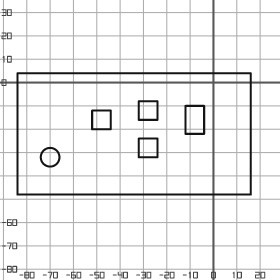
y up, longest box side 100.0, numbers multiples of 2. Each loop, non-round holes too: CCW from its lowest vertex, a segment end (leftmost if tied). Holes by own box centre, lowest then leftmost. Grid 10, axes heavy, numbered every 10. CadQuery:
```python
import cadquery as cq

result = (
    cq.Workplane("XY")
    .moveTo(-84.0, -48.0)
    .lineTo(16.0, -48.0)
    .lineTo(16.0, 4.0)
    .lineTo(-84.0, 4.0)
    .close()
    .moveTo(-70.0, -32.0)
    .circle(4.0)
    .moveTo(-32.0, -32.0)
    .lineTo(-24.0, -32.0)
    .lineTo(-24.0, -24.0)
    .lineTo(-32.0, -24.0)
    .close()
    .moveTo(-52.0, -20.0)
    .lineTo(-44.0, -20.0)
    .lineTo(-44.0, -12.0)
    .lineTo(-52.0, -12.0)
    .close()
    .moveTo(-12.0, -22.0)
    .lineTo(-4.0, -22.0)
    .lineTo(-4.0, -10.0)
    .lineTo(-12.0, -10.0)
    .close()
    .moveTo(-32.0, -16.0)
    .lineTo(-24.0, -16.0)
    .lineTo(-24.0, -8.0)
    .lineTo(-32.0, -8.0)
    .close()
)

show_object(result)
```